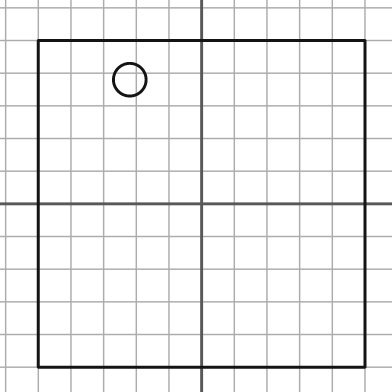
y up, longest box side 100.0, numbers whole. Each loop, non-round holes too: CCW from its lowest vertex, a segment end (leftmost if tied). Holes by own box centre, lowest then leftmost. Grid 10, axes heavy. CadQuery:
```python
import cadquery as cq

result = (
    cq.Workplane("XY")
    .moveTo(-50.0, -50.0)
    .lineTo(50.0, -50.0)
    .lineTo(50.0, 50.0)
    .lineTo(-50.0, 50.0)
    .close()
    .moveTo(-22.0, 38.0)
    .circle(5.0)
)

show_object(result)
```